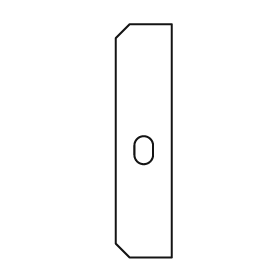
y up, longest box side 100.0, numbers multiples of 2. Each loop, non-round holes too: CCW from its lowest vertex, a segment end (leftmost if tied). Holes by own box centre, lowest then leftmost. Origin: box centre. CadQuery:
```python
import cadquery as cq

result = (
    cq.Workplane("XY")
    .moveTo(-6.0, -50.0)
    .lineTo(12.0, -50.0)
    .lineTo(12.0, 50.0)
    .lineTo(-6.0, 50.0)
    .lineTo(-12.0, 44.0)
    .lineTo(-12.0, -44.0)
    .close()
    .moveTo(-4.0, -6.0)
    .threePointArc((0.0, -10.0), (4.0, -6.0))
    .lineTo(4.0, -2.0)
    .threePointArc((0.0, 2.0), (-4.0, -2.0))
    .close()
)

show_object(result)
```